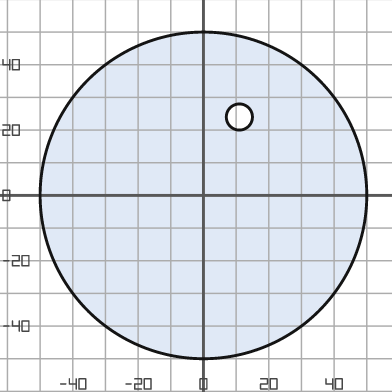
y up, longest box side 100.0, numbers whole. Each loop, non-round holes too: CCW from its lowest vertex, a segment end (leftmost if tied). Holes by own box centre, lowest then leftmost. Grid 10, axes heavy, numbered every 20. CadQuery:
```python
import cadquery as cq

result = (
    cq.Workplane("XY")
    .moveTo(0.0, 0.0)
    .circle(50.0)
    .moveTo(11.0, 24.0)
    .circle(4.0)
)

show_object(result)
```